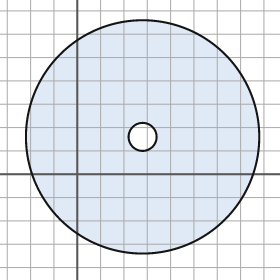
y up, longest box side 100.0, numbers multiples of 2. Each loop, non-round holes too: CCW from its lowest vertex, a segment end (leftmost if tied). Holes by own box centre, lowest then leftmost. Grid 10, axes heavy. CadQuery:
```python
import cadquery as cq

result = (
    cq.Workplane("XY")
    .moveTo(28.0, 16.0)
    .circle(50.0)
    .moveTo(28.0, 16.0)
    .circle(6.0)
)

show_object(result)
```